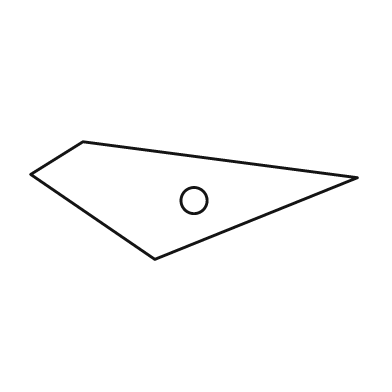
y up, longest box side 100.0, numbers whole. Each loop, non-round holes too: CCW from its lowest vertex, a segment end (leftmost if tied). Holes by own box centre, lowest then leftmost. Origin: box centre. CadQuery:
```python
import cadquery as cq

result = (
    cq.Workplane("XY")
    .moveTo(-12.0, -18.0)
    .lineTo(50.0, 7.0)
    .lineTo(-34.0, 18.0)
    .lineTo(-50.0, 8.0)
    .close()
    .moveTo(0.0, 0.0)
    .circle(4.0)
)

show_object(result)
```